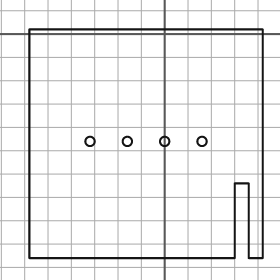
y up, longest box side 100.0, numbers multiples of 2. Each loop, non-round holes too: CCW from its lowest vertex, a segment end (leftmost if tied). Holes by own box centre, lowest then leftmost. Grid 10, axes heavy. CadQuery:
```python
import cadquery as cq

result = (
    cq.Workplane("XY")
    .moveTo(-58.0, -96.0)
    .lineTo(30.0, -96.0)
    .lineTo(30.0, -64.0)
    .lineTo(36.0, -64.0)
    .lineTo(36.0, -96.0)
    .lineTo(42.0, -96.0)
    .lineTo(42.0, 2.0)
    .lineTo(-58.0, 2.0)
    .close()
    .moveTo(-32.0, -46.0)
    .circle(2.0)
    .moveTo(-16.0, -46.0)
    .circle(2.0)
    .moveTo(0.0, -46.0)
    .circle(2.0)
    .moveTo(16.0, -46.0)
    .circle(2.0)
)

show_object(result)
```